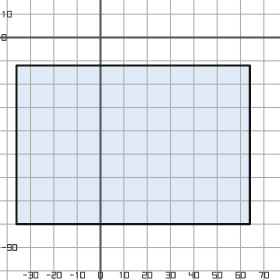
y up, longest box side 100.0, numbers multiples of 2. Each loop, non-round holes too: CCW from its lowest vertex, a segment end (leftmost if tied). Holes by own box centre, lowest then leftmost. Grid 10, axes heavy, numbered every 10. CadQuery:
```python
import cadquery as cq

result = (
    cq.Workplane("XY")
    .moveTo(-36.0, -80.0)
    .lineTo(64.0, -80.0)
    .lineTo(64.0, -12.0)
    .lineTo(-36.0, -12.0)
    .close()
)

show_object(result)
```